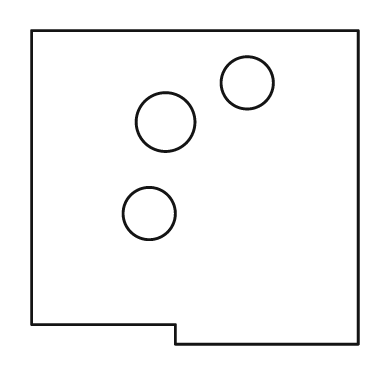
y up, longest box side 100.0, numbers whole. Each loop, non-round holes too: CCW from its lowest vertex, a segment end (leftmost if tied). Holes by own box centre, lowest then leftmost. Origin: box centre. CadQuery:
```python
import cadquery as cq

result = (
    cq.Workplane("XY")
    .moveTo(-6.0, -48.0)
    .lineTo(50.0, -48.0)
    .lineTo(50.0, 48.0)
    .lineTo(-50.0, 48.0)
    .lineTo(-50.0, -42.0)
    .lineTo(-6.0, -42.0)
    .close()
    .moveTo(-14.0, -8.0)
    .circle(8.0)
    .moveTo(-9.0, 20.0)
    .circle(9.0)
    .moveTo(16.0, 32.0)
    .circle(8.0)
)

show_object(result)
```